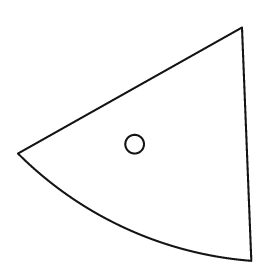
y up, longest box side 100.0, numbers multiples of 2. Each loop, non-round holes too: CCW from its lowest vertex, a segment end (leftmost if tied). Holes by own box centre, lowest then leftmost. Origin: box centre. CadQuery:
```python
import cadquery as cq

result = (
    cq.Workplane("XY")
    .moveTo(50.0, -50.0)
    .lineTo(46.0, 50.0)
    .lineTo(-50.0, -4.0)
    .threePointArc((-4.0, -36.0), (50.0, -50.0))
    .close()
    .moveTo(0.0, 0.0)
    .circle(4.0)
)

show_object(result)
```